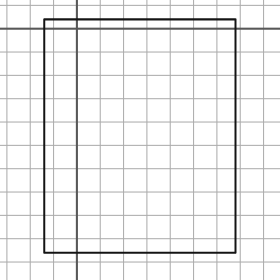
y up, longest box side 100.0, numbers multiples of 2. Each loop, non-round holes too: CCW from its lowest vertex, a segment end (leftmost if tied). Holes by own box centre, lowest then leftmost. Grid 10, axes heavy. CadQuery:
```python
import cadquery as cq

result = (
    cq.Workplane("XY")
    .moveTo(-14.0, -96.0)
    .lineTo(68.0, -96.0)
    .lineTo(68.0, 4.0)
    .lineTo(-14.0, 4.0)
    .close()
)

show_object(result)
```